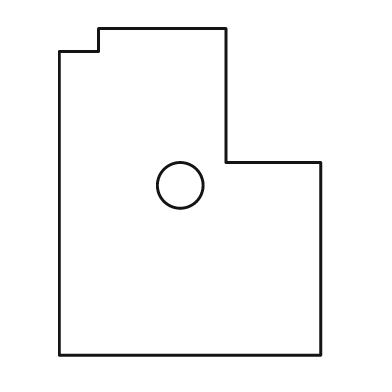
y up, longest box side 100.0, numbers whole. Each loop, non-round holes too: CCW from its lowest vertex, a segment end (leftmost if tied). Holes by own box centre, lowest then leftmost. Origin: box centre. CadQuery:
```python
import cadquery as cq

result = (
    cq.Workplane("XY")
    .moveTo(-40.0, -50.0)
    .lineTo(40.0, -50.0)
    .lineTo(40.0, 9.0)
    .lineTo(11.0, 9.0)
    .lineTo(11.0, 50.0)
    .lineTo(-28.0, 50.0)
    .lineTo(-28.0, 43.0)
    .lineTo(-40.0, 43.0)
    .close()
    .moveTo(-3.0, 2.0)
    .circle(7.0)
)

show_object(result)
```